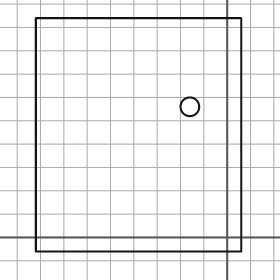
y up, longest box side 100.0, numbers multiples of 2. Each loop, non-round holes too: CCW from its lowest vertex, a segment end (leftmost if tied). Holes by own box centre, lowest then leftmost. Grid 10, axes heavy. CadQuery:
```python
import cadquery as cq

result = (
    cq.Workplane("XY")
    .moveTo(-82.0, -6.0)
    .lineTo(6.0, -6.0)
    .lineTo(6.0, 94.0)
    .lineTo(-82.0, 94.0)
    .close()
    .moveTo(-16.0, 56.0)
    .circle(4.0)
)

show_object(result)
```